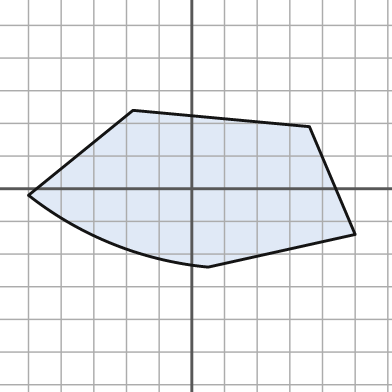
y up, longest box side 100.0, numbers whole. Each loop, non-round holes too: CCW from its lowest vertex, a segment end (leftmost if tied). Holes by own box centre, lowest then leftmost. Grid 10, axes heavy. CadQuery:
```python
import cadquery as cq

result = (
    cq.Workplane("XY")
    .moveTo(5.0, -24.0)
    .lineTo(50.0, -14.0)
    .lineTo(36.0, 19.0)
    .lineTo(-18.0, 24.0)
    .lineTo(-50.0, -2.0)
    .threePointArc((-24.0, -17.0), (5.0, -24.0))
    .close()
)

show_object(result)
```